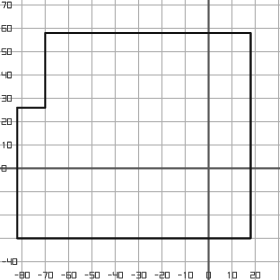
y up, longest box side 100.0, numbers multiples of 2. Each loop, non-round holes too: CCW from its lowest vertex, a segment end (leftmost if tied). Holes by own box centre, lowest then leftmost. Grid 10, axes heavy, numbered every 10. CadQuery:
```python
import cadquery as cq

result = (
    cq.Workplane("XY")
    .moveTo(-82.0, -30.0)
    .lineTo(18.0, -30.0)
    .lineTo(18.0, 58.0)
    .lineTo(-70.0, 58.0)
    .lineTo(-70.0, 26.0)
    .lineTo(-82.0, 26.0)
    .close()
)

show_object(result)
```